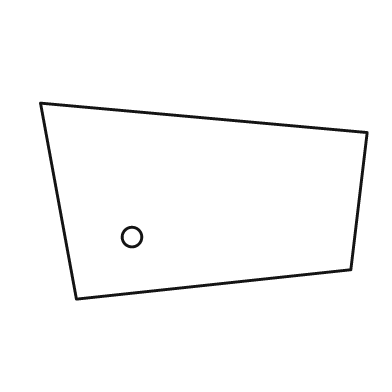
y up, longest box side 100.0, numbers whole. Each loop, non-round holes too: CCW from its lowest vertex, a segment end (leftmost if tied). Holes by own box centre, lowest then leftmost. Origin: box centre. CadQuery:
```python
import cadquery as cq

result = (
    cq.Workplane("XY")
    .moveTo(-39.0, -30.0)
    .lineTo(45.0, -21.0)
    .lineTo(50.0, 21.0)
    .lineTo(-50.0, 30.0)
    .close()
    .moveTo(-22.0, -11.0)
    .circle(3.0)
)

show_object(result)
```